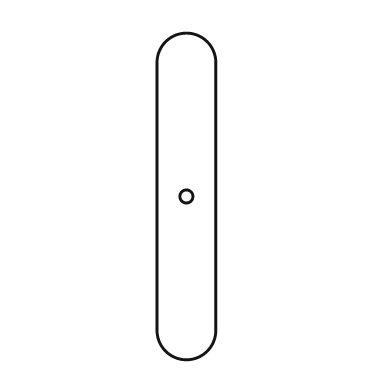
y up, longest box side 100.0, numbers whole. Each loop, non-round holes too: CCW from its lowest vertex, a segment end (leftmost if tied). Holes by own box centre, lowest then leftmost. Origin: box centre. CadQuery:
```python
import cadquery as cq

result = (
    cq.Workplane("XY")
    .moveTo(-9.0, -41.0)
    .threePointArc((0.0, -50.0), (9.0, -41.0))
    .lineTo(9.0, 41.0)
    .threePointArc((0.0, 50.0), (-9.0, 41.0))
    .close()
    .moveTo(0.0, 0.0)
    .circle(2.0)
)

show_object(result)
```